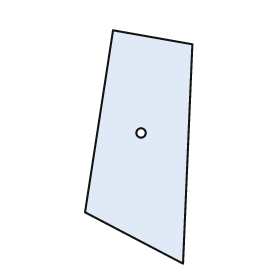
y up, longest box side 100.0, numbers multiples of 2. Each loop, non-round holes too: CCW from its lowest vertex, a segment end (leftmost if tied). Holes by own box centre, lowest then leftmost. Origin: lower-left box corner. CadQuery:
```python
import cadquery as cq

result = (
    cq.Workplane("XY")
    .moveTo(42.0, 0.0)
    .lineTo(46.0, 94.0)
    .lineTo(12.0, 100.0)
    .lineTo(0.0, 22.0)
    .close()
    .moveTo(24.0, 56.0)
    .circle(2.0)
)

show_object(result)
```